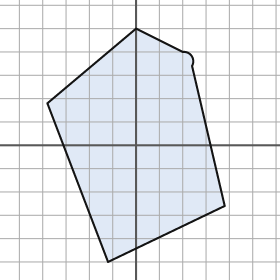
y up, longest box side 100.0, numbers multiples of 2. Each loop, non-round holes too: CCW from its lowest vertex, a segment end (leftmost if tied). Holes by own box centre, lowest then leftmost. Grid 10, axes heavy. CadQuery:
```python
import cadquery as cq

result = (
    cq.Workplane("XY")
    .moveTo(-12.0, -50.0)
    .lineTo(38.0, -26.0)
    .lineTo(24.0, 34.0)
    .threePointArc((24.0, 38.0), (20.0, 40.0))
    .lineTo(0.0, 50.0)
    .lineTo(-38.0, 18.0)
    .close()
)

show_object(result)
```